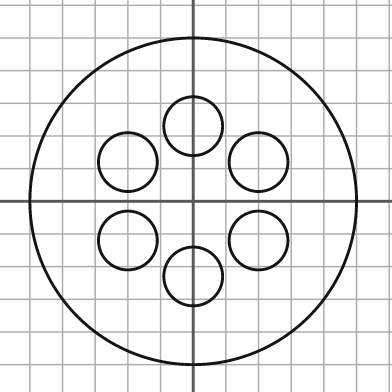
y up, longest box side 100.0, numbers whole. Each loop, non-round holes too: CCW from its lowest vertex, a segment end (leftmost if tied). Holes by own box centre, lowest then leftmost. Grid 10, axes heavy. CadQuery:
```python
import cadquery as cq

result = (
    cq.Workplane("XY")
    .moveTo(0.0, 0.0)
    .circle(50.0)
    .moveTo(0.0, -23.0)
    .circle(9.0)
    .moveTo(-20.0, -12.0)
    .circle(9.0)
    .moveTo(20.0, -12.0)
    .circle(9.0)
    .moveTo(-20.0, 12.0)
    .circle(9.0)
    .moveTo(20.0, 12.0)
    .circle(9.0)
    .moveTo(0.0, 23.0)
    .circle(9.0)
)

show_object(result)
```